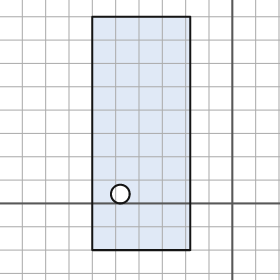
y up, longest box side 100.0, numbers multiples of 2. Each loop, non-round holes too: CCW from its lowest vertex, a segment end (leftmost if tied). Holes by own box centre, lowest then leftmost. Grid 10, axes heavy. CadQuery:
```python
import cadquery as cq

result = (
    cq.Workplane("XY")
    .moveTo(-60.0, -20.0)
    .lineTo(-18.0, -20.0)
    .lineTo(-18.0, 80.0)
    .lineTo(-60.0, 80.0)
    .close()
    .moveTo(-48.0, 4.0)
    .circle(4.0)
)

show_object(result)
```